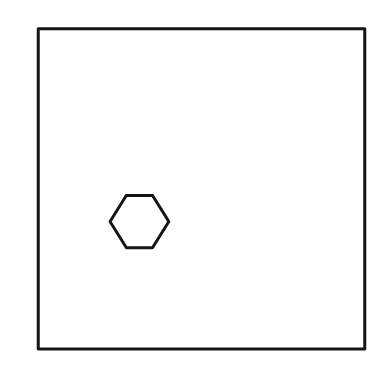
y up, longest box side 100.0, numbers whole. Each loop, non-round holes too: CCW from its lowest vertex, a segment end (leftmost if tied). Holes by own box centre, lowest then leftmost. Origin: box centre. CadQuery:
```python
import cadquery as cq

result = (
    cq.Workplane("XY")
    .moveTo(-50.0, -49.0)
    .lineTo(50.0, -49.0)
    .lineTo(50.0, 49.0)
    .lineTo(-50.0, 49.0)
    .close()
    .moveTo(-23.0, -18.0)
    .lineTo(-15.0, -18.0)
    .lineTo(-10.0, -10.0)
    .lineTo(-15.0, -2.0)
    .lineTo(-23.0, -2.0)
    .lineTo(-28.0, -10.0)
    .close()
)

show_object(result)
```